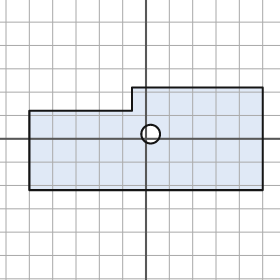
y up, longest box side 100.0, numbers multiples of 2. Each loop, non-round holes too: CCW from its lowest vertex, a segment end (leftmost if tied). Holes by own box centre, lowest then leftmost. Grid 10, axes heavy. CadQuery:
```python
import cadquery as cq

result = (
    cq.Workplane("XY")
    .moveTo(-50.0, -22.0)
    .lineTo(50.0, -22.0)
    .lineTo(50.0, 22.0)
    .lineTo(-6.0, 22.0)
    .lineTo(-6.0, 12.0)
    .lineTo(-50.0, 12.0)
    .close()
    .moveTo(2.0, 2.0)
    .circle(4.0)
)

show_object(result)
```